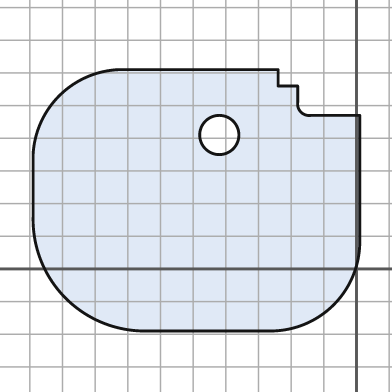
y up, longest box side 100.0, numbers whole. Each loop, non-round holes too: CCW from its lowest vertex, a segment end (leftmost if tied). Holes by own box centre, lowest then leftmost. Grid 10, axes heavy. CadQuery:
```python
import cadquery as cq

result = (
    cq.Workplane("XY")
    .moveTo(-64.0, -19.0)
    .lineTo(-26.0, -19.0)
    .threePointArc((-7.0, -11.0), (1.0, 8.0))
    .lineTo(1.0, 47.0)
    .lineTo(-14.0, 47.0)
    .threePointArc((-17.0, 48.0), (-18.0, 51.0))
    .lineTo(-18.0, 56.0)
    .lineTo(-24.0, 56.0)
    .lineTo(-24.0, 61.0)
    .lineTo(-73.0, 61.0)
    .threePointArc((-91.0, 53.0), (-99.0, 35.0))
    .lineTo(-99.0, 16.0)
    .threePointArc((-89.0, -9.0), (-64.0, -19.0))
    .close()
    .moveTo(-42.0, 41.0)
    .circle(6.0)
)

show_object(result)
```